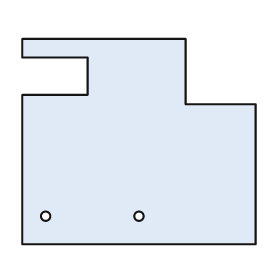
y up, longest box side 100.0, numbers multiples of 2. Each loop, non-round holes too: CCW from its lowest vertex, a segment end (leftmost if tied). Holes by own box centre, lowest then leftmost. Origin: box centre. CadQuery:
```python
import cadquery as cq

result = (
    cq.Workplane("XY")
    .moveTo(-50.0, -44.0)
    .lineTo(50.0, -44.0)
    .lineTo(50.0, 16.0)
    .lineTo(20.0, 16.0)
    .lineTo(20.0, 44.0)
    .lineTo(-50.0, 44.0)
    .lineTo(-50.0, 36.0)
    .lineTo(-22.0, 36.0)
    .lineTo(-22.0, 20.0)
    .lineTo(-50.0, 20.0)
    .close()
    .moveTo(-40.0, -32.0)
    .circle(2.0)
    .moveTo(0.0, -32.0)
    .circle(2.0)
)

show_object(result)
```